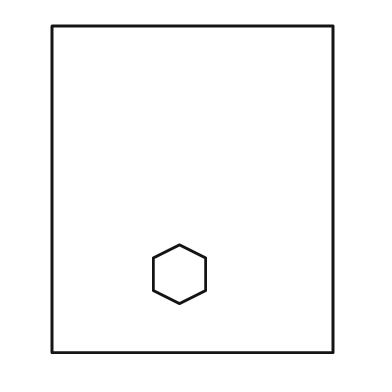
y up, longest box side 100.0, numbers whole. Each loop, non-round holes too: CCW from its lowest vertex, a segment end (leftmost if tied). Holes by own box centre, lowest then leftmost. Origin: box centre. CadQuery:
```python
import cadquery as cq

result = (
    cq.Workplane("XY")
    .moveTo(-43.0, -50.0)
    .lineTo(43.0, -50.0)
    .lineTo(43.0, 50.0)
    .lineTo(-43.0, 50.0)
    .close()
    .moveTo(-4.0, -35.0)
    .lineTo(4.0, -31.0)
    .lineTo(4.0, -21.0)
    .lineTo(-4.0, -17.0)
    .lineTo(-12.0, -21.0)
    .lineTo(-12.0, -31.0)
    .close()
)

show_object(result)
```